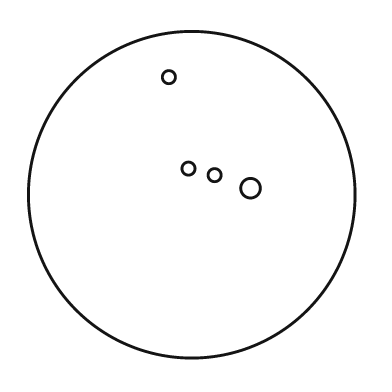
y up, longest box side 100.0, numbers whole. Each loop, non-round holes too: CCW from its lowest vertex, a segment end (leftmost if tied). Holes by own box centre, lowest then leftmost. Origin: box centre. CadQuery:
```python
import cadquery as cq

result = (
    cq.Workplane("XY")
    .moveTo(0.0, 0.0)
    .circle(50.0)
    .moveTo(18.0, 2.0)
    .circle(3.0)
    .moveTo(7.0, 6.0)
    .circle(2.0)
    .moveTo(-1.0, 8.0)
    .circle(2.0)
    .moveTo(-7.0, 36.0)
    .circle(2.0)
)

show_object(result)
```